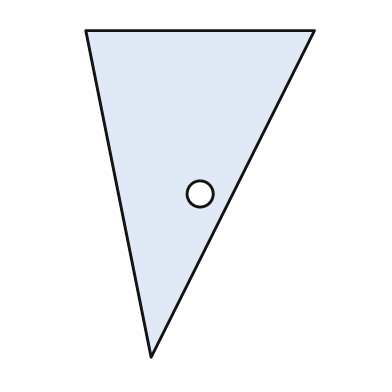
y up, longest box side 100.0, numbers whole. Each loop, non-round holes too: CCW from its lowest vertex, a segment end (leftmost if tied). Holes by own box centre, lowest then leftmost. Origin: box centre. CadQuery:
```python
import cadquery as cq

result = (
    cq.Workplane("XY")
    .moveTo(-15.0, -50.0)
    .lineTo(35.0, 50.0)
    .lineTo(-35.0, 50.0)
    .close()
    .moveTo(0.0, 0.0)
    .circle(4.0)
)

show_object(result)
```